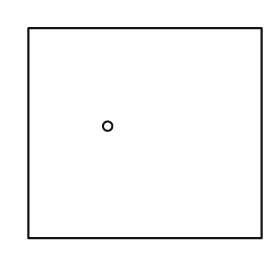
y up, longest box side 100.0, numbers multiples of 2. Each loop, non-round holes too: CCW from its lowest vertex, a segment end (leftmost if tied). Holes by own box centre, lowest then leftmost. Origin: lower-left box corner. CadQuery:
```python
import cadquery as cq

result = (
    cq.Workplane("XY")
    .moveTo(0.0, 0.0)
    .lineTo(100.0, 0.0)
    .lineTo(100.0, 90.0)
    .lineTo(0.0, 90.0)
    .close()
    .moveTo(34.0, 48.0)
    .circle(2.0)
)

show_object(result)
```